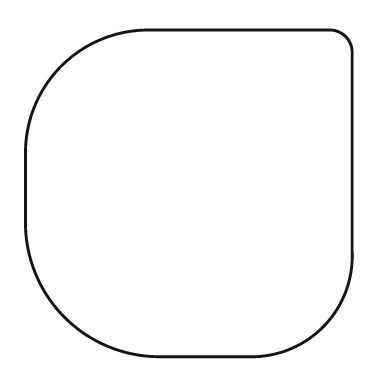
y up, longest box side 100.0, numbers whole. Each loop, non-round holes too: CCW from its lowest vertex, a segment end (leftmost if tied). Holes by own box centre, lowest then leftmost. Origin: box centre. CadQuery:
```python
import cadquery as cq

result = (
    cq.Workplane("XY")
    .moveTo(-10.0, -50.0)
    .lineTo(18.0, -50.0)
    .threePointArc((41.0, -41.0), (50.0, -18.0))
    .lineTo(50.0, 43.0)
    .threePointArc((48.0, 48.0), (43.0, 50.0))
    .lineTo(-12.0, 50.0)
    .threePointArc((-39.0, 39.0), (-50.0, 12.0))
    .lineTo(-50.0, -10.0)
    .threePointArc((-38.0, -38.0), (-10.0, -50.0))
    .close()
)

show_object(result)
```